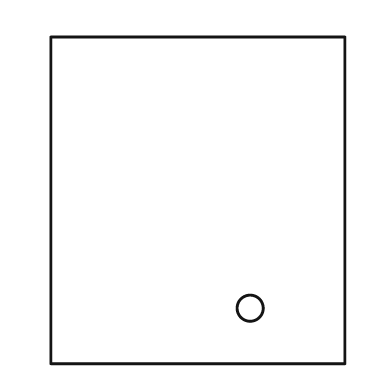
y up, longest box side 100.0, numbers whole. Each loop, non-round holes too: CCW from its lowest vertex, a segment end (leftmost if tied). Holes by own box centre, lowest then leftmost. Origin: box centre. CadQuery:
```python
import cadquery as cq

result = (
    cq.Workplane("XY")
    .moveTo(-45.0, -50.0)
    .lineTo(45.0, -50.0)
    .lineTo(45.0, 50.0)
    .lineTo(-45.0, 50.0)
    .close()
    .moveTo(16.0, -33.0)
    .circle(4.0)
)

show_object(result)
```